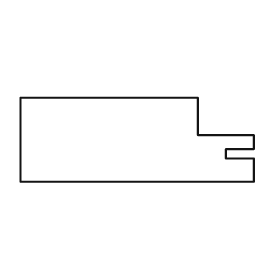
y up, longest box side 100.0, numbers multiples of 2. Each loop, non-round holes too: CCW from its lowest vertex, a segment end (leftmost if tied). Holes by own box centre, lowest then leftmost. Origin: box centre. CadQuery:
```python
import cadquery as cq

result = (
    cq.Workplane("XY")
    .moveTo(-50.0, -18.0)
    .lineTo(50.0, -18.0)
    .lineTo(50.0, -8.0)
    .lineTo(38.0, -8.0)
    .lineTo(38.0, -4.0)
    .lineTo(50.0, -4.0)
    .lineTo(50.0, 2.0)
    .lineTo(26.0, 2.0)
    .lineTo(26.0, 18.0)
    .lineTo(-50.0, 18.0)
    .close()
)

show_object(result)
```